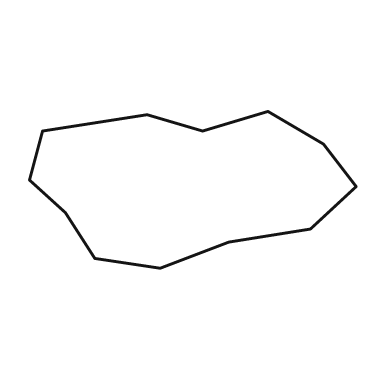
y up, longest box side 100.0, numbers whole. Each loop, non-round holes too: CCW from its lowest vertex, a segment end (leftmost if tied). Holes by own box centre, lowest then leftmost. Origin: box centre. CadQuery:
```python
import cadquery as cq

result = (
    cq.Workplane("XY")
    .moveTo(-10.0, -24.0)
    .lineTo(11.0, -16.0)
    .lineTo(36.0, -12.0)
    .lineTo(50.0, 1.0)
    .lineTo(40.0, 14.0)
    .lineTo(23.0, 24.0)
    .lineTo(3.0, 18.0)
    .lineTo(-14.0, 23.0)
    .lineTo(-46.0, 18.0)
    .lineTo(-50.0, 3.0)
    .lineTo(-39.0, -7.0)
    .lineTo(-30.0, -21.0)
    .close()
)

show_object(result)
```